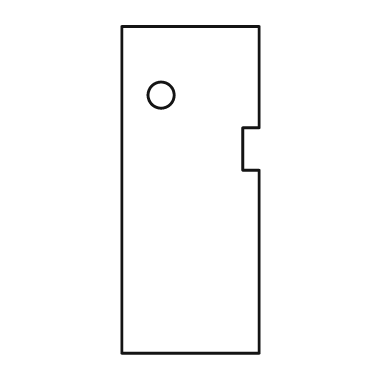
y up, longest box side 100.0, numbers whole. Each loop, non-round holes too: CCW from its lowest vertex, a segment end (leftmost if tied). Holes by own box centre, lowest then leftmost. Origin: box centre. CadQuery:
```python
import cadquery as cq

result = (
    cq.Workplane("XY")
    .moveTo(-21.0, -50.0)
    .lineTo(21.0, -50.0)
    .lineTo(21.0, 6.0)
    .lineTo(16.0, 6.0)
    .lineTo(16.0, 19.0)
    .lineTo(21.0, 19.0)
    .lineTo(21.0, 50.0)
    .lineTo(-21.0, 50.0)
    .close()
    .moveTo(-9.0, 29.0)
    .circle(4.0)
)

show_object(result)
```